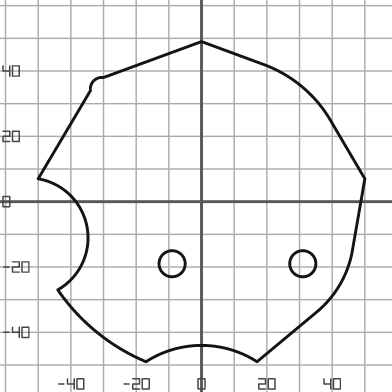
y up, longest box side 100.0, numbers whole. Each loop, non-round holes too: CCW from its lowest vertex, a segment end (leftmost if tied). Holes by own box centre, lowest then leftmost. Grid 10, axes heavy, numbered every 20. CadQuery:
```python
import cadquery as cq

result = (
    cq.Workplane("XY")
    .moveTo(-17.0, -49.0)
    .threePointArc((0.0, -44.0), (17.0, -49.0))
    .lineTo(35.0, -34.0)
    .threePointArc((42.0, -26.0), (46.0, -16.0))
    .lineTo(50.0, 7.0)
    .lineTo(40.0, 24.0)
    .threePointArc((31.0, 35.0), (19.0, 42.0))
    .lineTo(0.0, 49.0)
    .lineTo(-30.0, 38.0)
    .threePointArc((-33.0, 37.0), (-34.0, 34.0))
    .lineTo(-50.0, 7.0)
    .threePointArc((-35.0, -8.0), (-44.0, -27.0))
    .threePointArc((-32.0, -40.0), (-17.0, -49.0))
    .close()
    .moveTo(-9.0, -19.0)
    .circle(4.0)
    .moveTo(31.0, -19.0)
    .circle(4.0)
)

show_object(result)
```